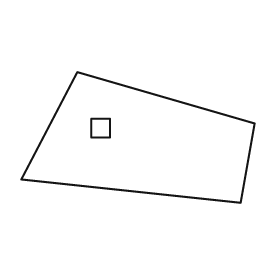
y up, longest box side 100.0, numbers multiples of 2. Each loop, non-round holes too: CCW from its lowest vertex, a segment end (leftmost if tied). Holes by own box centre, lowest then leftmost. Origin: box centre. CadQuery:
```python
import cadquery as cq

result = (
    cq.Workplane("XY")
    .moveTo(44.0, -28.0)
    .lineTo(50.0, 6.0)
    .lineTo(-26.0, 28.0)
    .lineTo(-50.0, -18.0)
    .close()
    .moveTo(-20.0, 0.0)
    .lineTo(-12.0, 0.0)
    .lineTo(-12.0, 8.0)
    .lineTo(-20.0, 8.0)
    .close()
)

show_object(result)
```